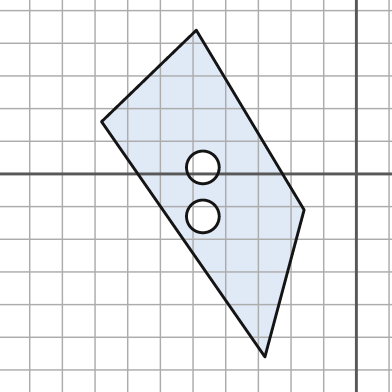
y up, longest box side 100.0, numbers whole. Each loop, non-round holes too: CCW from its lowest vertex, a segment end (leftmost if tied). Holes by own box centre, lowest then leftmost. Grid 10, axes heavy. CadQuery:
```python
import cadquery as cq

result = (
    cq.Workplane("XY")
    .moveTo(-28.0, -56.0)
    .lineTo(-16.0, -11.0)
    .lineTo(-49.0, 44.0)
    .lineTo(-78.0, 16.0)
    .close()
    .moveTo(-47.0, -13.0)
    .circle(5.0)
    .moveTo(-47.0, 2.0)
    .circle(5.0)
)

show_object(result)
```